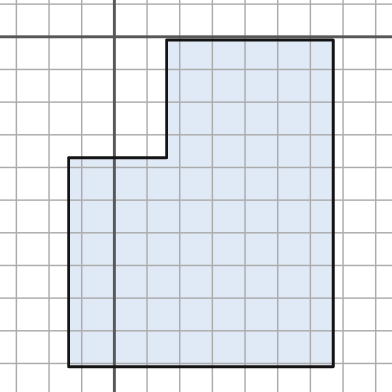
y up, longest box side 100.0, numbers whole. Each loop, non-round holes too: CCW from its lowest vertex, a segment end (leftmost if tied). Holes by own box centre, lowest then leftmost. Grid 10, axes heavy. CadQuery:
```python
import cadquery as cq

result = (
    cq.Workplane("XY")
    .moveTo(-14.0, -101.0)
    .lineTo(67.0, -101.0)
    .lineTo(67.0, -1.0)
    .lineTo(16.0, -1.0)
    .lineTo(16.0, -37.0)
    .lineTo(-14.0, -37.0)
    .close()
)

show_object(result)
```